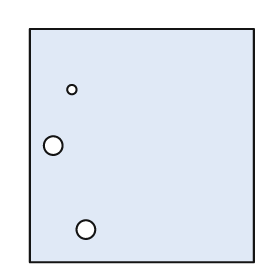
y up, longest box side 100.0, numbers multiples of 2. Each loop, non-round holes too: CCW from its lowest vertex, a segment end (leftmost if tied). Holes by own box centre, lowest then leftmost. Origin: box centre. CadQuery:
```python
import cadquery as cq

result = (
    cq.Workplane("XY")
    .moveTo(-48.0, -50.0)
    .lineTo(48.0, -50.0)
    .lineTo(48.0, 50.0)
    .lineTo(-48.0, 50.0)
    .close()
    .moveTo(-24.0, -36.0)
    .circle(4.0)
    .moveTo(-38.0, 0.0)
    .circle(4.0)
    .moveTo(-30.0, 24.0)
    .circle(2.0)
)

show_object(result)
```